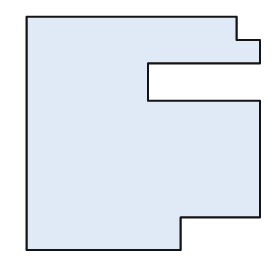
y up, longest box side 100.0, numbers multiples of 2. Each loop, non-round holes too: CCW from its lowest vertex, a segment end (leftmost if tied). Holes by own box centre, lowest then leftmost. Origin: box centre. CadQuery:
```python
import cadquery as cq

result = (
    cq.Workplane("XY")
    .moveTo(-50.0, -50.0)
    .lineTo(16.0, -50.0)
    .lineTo(16.0, -36.0)
    .lineTo(50.0, -36.0)
    .lineTo(50.0, 14.0)
    .lineTo(2.0, 14.0)
    .lineTo(2.0, 30.0)
    .lineTo(50.0, 30.0)
    .lineTo(50.0, 40.0)
    .lineTo(40.0, 40.0)
    .lineTo(40.0, 50.0)
    .lineTo(-50.0, 50.0)
    .close()
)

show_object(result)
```